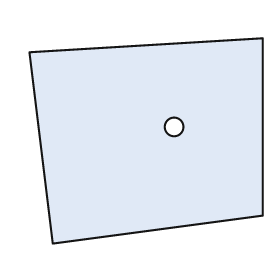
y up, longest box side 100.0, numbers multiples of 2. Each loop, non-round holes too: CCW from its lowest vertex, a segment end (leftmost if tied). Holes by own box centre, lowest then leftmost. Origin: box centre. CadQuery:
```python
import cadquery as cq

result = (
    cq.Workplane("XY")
    .moveTo(-40.0, -44.0)
    .lineTo(50.0, -32.0)
    .lineTo(50.0, 44.0)
    .lineTo(-50.0, 38.0)
    .close()
    .moveTo(12.0, 6.0)
    .circle(4.0)
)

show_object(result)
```